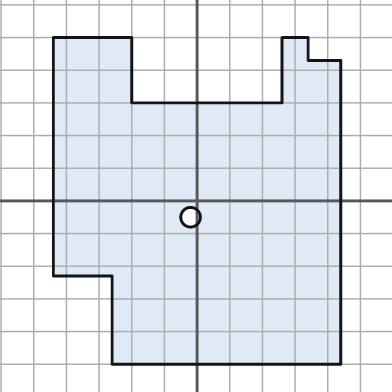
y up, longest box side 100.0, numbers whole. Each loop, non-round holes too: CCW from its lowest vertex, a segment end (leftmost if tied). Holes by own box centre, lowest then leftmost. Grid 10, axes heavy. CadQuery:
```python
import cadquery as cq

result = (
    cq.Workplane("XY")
    .moveTo(-26.0, -50.0)
    .lineTo(44.0, -50.0)
    .lineTo(44.0, 43.0)
    .lineTo(34.0, 43.0)
    .lineTo(34.0, 50.0)
    .lineTo(26.0, 50.0)
    .lineTo(26.0, 30.0)
    .lineTo(-20.0, 30.0)
    .lineTo(-20.0, 50.0)
    .lineTo(-44.0, 50.0)
    .lineTo(-44.0, -23.0)
    .lineTo(-26.0, -23.0)
    .close()
    .moveTo(-2.0, -5.0)
    .circle(3.0)
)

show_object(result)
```